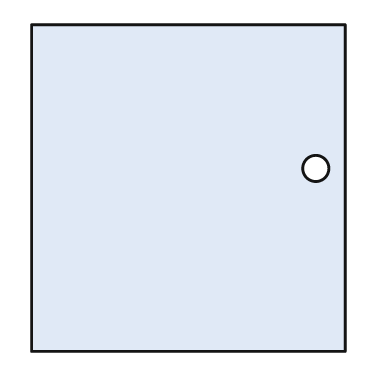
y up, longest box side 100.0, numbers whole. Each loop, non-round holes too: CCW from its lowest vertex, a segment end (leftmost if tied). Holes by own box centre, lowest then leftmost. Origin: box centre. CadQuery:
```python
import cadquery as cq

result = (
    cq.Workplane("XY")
    .moveTo(-48.0, -50.0)
    .lineTo(48.0, -50.0)
    .lineTo(48.0, 50.0)
    .lineTo(-48.0, 50.0)
    .close()
    .moveTo(39.0, 6.0)
    .circle(4.0)
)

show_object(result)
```